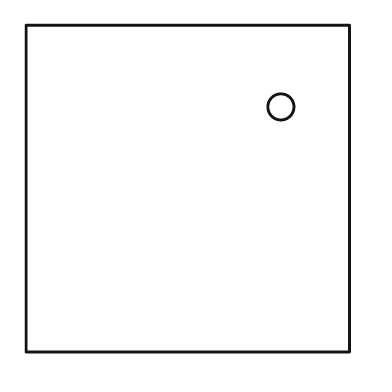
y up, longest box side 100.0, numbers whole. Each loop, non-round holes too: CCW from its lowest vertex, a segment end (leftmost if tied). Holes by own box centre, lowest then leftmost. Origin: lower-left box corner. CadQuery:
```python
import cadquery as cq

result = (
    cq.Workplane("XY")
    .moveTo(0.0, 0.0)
    .lineTo(99.0, 0.0)
    .lineTo(99.0, 100.0)
    .lineTo(0.0, 100.0)
    .close()
    .moveTo(78.0, 75.0)
    .circle(4.0)
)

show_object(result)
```